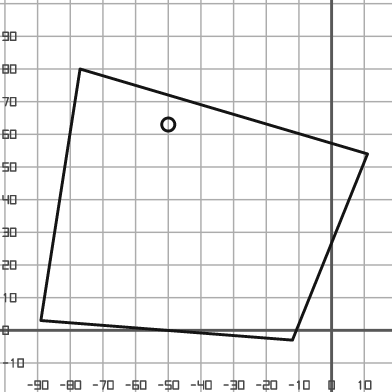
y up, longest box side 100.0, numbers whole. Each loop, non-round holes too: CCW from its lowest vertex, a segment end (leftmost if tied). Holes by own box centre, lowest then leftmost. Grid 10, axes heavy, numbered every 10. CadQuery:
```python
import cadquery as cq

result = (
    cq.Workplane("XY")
    .moveTo(-12.0, -3.0)
    .lineTo(11.0, 54.0)
    .lineTo(-77.0, 80.0)
    .lineTo(-89.0, 3.0)
    .close()
    .moveTo(-50.0, 63.0)
    .circle(2.0)
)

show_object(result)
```